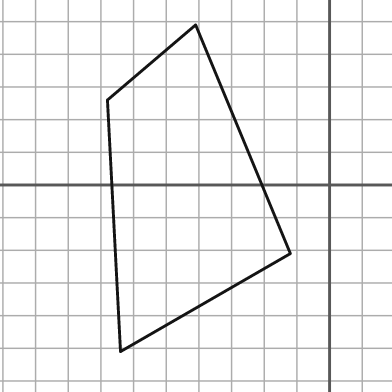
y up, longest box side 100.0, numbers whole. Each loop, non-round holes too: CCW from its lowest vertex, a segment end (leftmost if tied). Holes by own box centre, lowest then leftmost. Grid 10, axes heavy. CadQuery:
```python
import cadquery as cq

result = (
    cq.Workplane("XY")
    .moveTo(-64.0, -51.0)
    .lineTo(-12.0, -21.0)
    .lineTo(-41.0, 49.0)
    .lineTo(-68.0, 26.0)
    .close()
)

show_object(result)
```